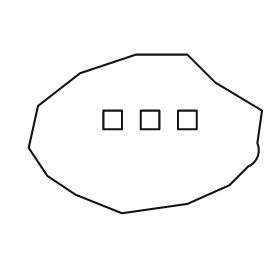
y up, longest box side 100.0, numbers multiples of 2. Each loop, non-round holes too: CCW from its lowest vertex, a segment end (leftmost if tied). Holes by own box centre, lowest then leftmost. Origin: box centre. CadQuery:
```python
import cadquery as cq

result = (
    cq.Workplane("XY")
    .moveTo(-10.0, -34.0)
    .lineTo(18.0, -30.0)
    .lineTo(36.0, -22.0)
    .lineTo(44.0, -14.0)
    .threePointArc((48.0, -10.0), (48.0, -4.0))
    .lineTo(50.0, 10.0)
    .lineTo(30.0, 22.0)
    .lineTo(18.0, 34.0)
    .lineTo(-4.0, 34.0)
    .lineTo(-28.0, 26.0)
    .lineTo(-46.0, 12.0)
    .lineTo(-50.0, -6.0)
    .lineTo(-42.0, -18.0)
    .lineTo(-30.0, -26.0)
    .close()
    .moveTo(-18.0, 2.0)
    .lineTo(-10.0, 2.0)
    .lineTo(-10.0, 10.0)
    .lineTo(-18.0, 10.0)
    .close()
    .moveTo(-2.0, 2.0)
    .lineTo(6.0, 2.0)
    .lineTo(6.0, 10.0)
    .lineTo(-2.0, 10.0)
    .close()
    .moveTo(14.0, 2.0)
    .lineTo(22.0, 2.0)
    .lineTo(22.0, 10.0)
    .lineTo(14.0, 10.0)
    .close()
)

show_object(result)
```